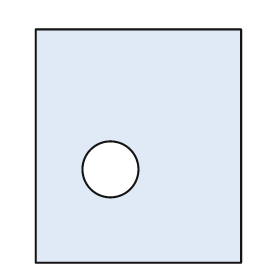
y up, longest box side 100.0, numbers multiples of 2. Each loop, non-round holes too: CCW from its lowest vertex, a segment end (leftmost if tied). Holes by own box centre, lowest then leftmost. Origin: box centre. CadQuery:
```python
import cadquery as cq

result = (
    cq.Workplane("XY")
    .moveTo(-44.0, -50.0)
    .lineTo(44.0, -50.0)
    .lineTo(44.0, 50.0)
    .lineTo(-44.0, 50.0)
    .close()
    .moveTo(-12.0, -10.0)
    .circle(12.0)
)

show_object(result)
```